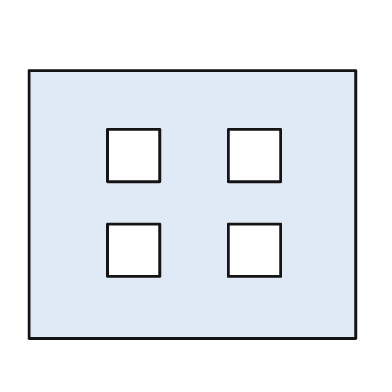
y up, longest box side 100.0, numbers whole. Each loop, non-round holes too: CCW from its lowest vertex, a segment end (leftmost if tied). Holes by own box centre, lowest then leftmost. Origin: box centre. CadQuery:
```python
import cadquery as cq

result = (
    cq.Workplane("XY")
    .moveTo(-50.0, -41.0)
    .lineTo(50.0, -41.0)
    .lineTo(50.0, 41.0)
    .lineTo(-50.0, 41.0)
    .close()
    .moveTo(-26.0, -22.0)
    .lineTo(-10.0, -22.0)
    .lineTo(-10.0, -6.0)
    .lineTo(-26.0, -6.0)
    .close()
    .moveTo(11.0, -22.0)
    .lineTo(27.0, -22.0)
    .lineTo(27.0, -6.0)
    .lineTo(11.0, -6.0)
    .close()
    .moveTo(-26.0, 7.0)
    .lineTo(-10.0, 7.0)
    .lineTo(-10.0, 23.0)
    .lineTo(-26.0, 23.0)
    .close()
    .moveTo(11.0, 7.0)
    .lineTo(27.0, 7.0)
    .lineTo(27.0, 23.0)
    .lineTo(11.0, 23.0)
    .close()
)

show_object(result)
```